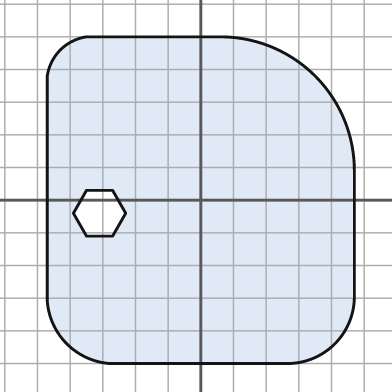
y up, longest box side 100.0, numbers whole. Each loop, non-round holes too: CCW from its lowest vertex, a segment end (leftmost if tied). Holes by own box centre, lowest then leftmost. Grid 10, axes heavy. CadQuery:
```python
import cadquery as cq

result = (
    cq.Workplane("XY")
    .moveTo(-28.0, -50.0)
    .lineTo(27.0, -50.0)
    .threePointArc((41.0, -44.0), (47.0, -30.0))
    .lineTo(47.0, 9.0)
    .threePointArc((35.0, 38.0), (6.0, 50.0))
    .lineTo(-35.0, 50.0)
    .threePointArc((-43.0, 46.0), (-47.0, 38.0))
    .lineTo(-47.0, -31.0)
    .threePointArc((-41.0, -44.0), (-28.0, -50.0))
    .close()
    .moveTo(-35.0, -11.0)
    .lineTo(-27.0, -11.0)
    .lineTo(-23.0, -4.0)
    .lineTo(-27.0, 3.0)
    .lineTo(-35.0, 3.0)
    .lineTo(-39.0, -4.0)
    .close()
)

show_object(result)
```